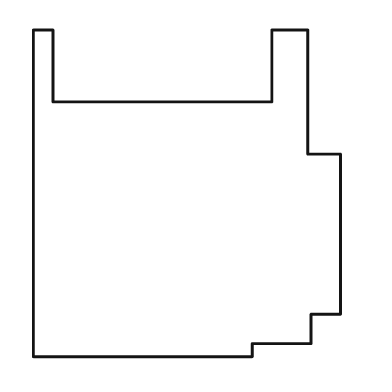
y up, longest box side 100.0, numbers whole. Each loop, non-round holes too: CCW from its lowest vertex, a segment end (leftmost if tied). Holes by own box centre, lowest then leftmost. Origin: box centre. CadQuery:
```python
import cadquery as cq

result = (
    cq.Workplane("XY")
    .moveTo(-47.0, -50.0)
    .lineTo(20.0, -50.0)
    .lineTo(20.0, -46.0)
    .lineTo(38.0, -46.0)
    .lineTo(38.0, -37.0)
    .lineTo(47.0, -37.0)
    .lineTo(47.0, 12.0)
    .lineTo(37.0, 12.0)
    .lineTo(37.0, 50.0)
    .lineTo(26.0, 50.0)
    .lineTo(26.0, 28.0)
    .lineTo(-41.0, 28.0)
    .lineTo(-41.0, 50.0)
    .lineTo(-47.0, 50.0)
    .close()
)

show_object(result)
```